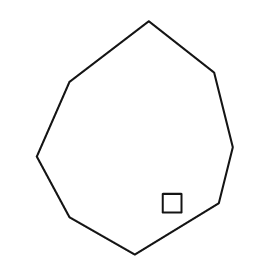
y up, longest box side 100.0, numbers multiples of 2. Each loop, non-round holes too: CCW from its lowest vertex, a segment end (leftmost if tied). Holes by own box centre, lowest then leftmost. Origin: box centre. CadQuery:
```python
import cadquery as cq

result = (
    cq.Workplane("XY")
    .moveTo(0.0, -50.0)
    .lineTo(36.0, -28.0)
    .lineTo(42.0, -4.0)
    .lineTo(34.0, 28.0)
    .lineTo(6.0, 50.0)
    .lineTo(-28.0, 24.0)
    .lineTo(-42.0, -8.0)
    .lineTo(-28.0, -34.0)
    .close()
    .moveTo(12.0, -32.0)
    .lineTo(20.0, -32.0)
    .lineTo(20.0, -24.0)
    .lineTo(12.0, -24.0)
    .close()
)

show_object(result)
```